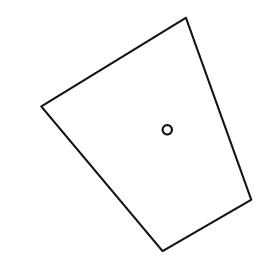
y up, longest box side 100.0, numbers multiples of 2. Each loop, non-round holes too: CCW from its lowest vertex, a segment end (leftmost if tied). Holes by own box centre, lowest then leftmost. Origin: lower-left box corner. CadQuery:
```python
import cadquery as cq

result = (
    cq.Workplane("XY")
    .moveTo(52.0, 0.0)
    .lineTo(90.0, 22.0)
    .lineTo(62.0, 100.0)
    .lineTo(0.0, 62.0)
    .close()
    .moveTo(54.0, 52.0)
    .circle(2.0)
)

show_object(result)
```